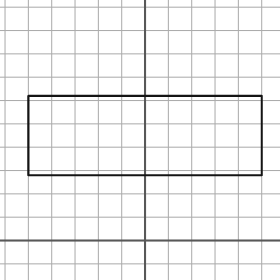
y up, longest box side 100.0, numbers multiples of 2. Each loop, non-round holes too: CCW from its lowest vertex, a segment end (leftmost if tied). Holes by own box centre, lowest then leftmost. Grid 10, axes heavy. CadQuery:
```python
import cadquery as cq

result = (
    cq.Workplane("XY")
    .moveTo(-50.0, 28.0)
    .lineTo(50.0, 28.0)
    .lineTo(50.0, 62.0)
    .lineTo(-50.0, 62.0)
    .close()
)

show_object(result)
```